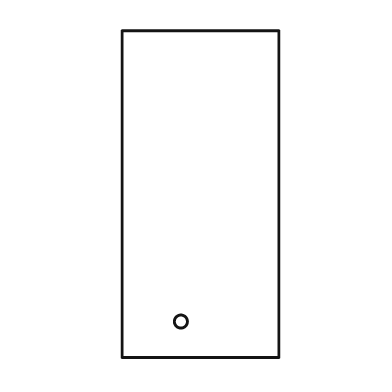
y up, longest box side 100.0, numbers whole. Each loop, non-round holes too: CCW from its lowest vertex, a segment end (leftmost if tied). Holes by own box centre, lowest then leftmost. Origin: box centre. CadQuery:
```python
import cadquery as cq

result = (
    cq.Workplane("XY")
    .moveTo(-24.0, -50.0)
    .lineTo(24.0, -50.0)
    .lineTo(24.0, 50.0)
    .lineTo(-24.0, 50.0)
    .close()
    .moveTo(-6.0, -39.0)
    .circle(2.0)
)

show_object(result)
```